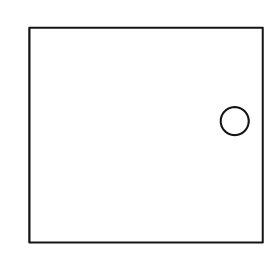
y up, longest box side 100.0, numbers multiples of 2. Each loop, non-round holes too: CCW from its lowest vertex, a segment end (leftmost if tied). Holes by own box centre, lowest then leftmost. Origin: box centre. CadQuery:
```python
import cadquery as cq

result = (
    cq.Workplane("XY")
    .moveTo(-50.0, -46.0)
    .lineTo(50.0, -46.0)
    .lineTo(50.0, 46.0)
    .lineTo(-50.0, 46.0)
    .close()
    .moveTo(38.0, 6.0)
    .circle(6.0)
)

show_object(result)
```